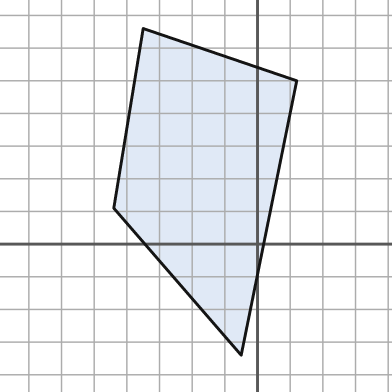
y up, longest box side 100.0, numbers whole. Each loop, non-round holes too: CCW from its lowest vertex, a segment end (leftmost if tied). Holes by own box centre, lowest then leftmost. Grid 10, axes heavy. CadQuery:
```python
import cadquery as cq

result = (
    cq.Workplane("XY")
    .moveTo(-5.0, -34.0)
    .lineTo(12.0, 50.0)
    .lineTo(-35.0, 66.0)
    .lineTo(-44.0, 11.0)
    .close()
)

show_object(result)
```